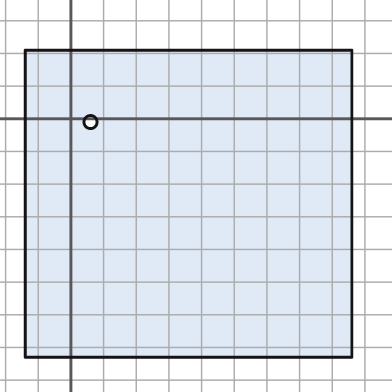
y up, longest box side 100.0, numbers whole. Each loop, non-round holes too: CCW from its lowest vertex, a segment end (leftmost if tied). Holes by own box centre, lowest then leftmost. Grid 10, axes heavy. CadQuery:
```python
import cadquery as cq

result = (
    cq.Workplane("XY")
    .moveTo(-14.0, -73.0)
    .lineTo(86.0, -73.0)
    .lineTo(86.0, 21.0)
    .lineTo(-14.0, 21.0)
    .close()
    .moveTo(6.0, -1.0)
    .circle(2.0)
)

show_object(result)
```